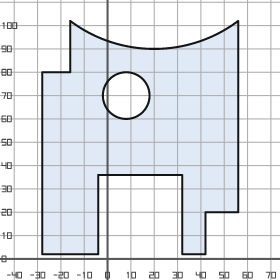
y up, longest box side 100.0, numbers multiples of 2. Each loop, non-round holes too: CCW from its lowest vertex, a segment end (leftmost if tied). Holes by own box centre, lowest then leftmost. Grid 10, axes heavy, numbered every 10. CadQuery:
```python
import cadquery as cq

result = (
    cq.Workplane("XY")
    .moveTo(-28.0, 2.0)
    .lineTo(-4.0, 2.0)
    .lineTo(-4.0, 36.0)
    .lineTo(32.0, 36.0)
    .lineTo(32.0, 2.0)
    .lineTo(42.0, 2.0)
    .lineTo(42.0, 20.0)
    .lineTo(56.0, 20.0)
    .lineTo(56.0, 102.0)
    .threePointArc((20.0, 90.0), (-16.0, 102.0))
    .lineTo(-16.0, 80.0)
    .lineTo(-28.0, 80.0)
    .close()
    .moveTo(8.0, 70.0)
    .circle(10.0)
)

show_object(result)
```